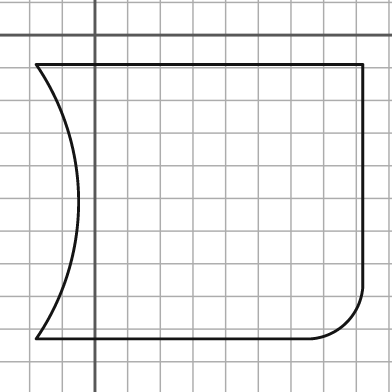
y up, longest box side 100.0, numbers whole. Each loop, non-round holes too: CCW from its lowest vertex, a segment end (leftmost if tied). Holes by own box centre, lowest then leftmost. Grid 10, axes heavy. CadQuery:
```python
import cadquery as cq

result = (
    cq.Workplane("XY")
    .moveTo(-18.0, -93.0)
    .lineTo(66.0, -93.0)
    .threePointArc((77.0, -88.0), (82.0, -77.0))
    .lineTo(82.0, -9.0)
    .lineTo(-18.0, -9.0)
    .threePointArc((-5.0, -51.0), (-18.0, -93.0))
    .close()
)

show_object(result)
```